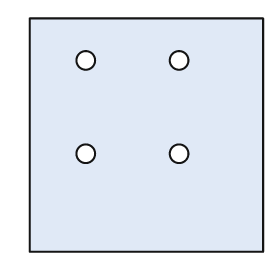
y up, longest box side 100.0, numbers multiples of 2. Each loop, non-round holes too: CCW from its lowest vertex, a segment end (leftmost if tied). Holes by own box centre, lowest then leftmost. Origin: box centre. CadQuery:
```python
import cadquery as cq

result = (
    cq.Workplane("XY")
    .moveTo(-50.0, -50.0)
    .lineTo(50.0, -50.0)
    .lineTo(50.0, 50.0)
    .lineTo(-50.0, 50.0)
    .close()
    .moveTo(-26.0, -8.0)
    .circle(4.0)
    .moveTo(14.0, -8.0)
    .circle(4.0)
    .moveTo(-26.0, 32.0)
    .circle(4.0)
    .moveTo(14.0, 32.0)
    .circle(4.0)
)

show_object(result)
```